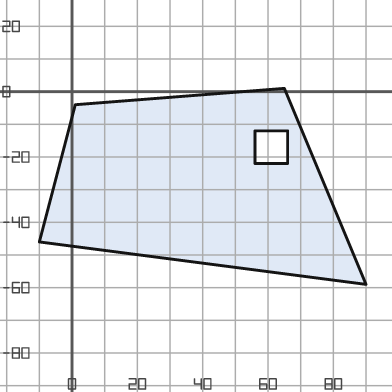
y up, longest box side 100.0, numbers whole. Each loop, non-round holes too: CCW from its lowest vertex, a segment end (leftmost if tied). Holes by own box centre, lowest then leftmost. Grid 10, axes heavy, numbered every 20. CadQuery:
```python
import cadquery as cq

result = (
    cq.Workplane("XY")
    .moveTo(90.0, -59.0)
    .lineTo(65.0, 1.0)
    .lineTo(1.0, -4.0)
    .lineTo(-10.0, -46.0)
    .close()
    .moveTo(56.0, -22.0)
    .lineTo(66.0, -22.0)
    .lineTo(66.0, -12.0)
    .lineTo(56.0, -12.0)
    .close()
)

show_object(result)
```